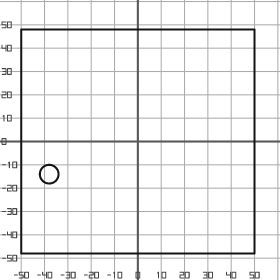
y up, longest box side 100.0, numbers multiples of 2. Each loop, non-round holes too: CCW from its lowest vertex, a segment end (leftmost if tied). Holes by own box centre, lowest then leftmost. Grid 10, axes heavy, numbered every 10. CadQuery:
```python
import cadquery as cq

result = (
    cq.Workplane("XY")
    .moveTo(-50.0, -48.0)
    .lineTo(50.0, -48.0)
    .lineTo(50.0, 48.0)
    .lineTo(-50.0, 48.0)
    .close()
    .moveTo(-38.0, -14.0)
    .circle(4.0)
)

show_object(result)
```